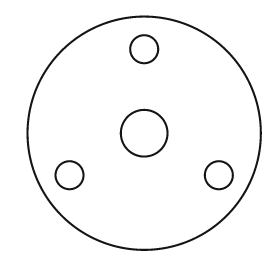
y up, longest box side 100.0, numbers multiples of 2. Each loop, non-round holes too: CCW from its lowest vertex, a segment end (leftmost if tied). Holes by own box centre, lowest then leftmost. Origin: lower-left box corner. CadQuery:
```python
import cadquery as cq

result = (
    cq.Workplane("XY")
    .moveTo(50.0, 50.0)
    .circle(50.0)
    .moveTo(18.0, 32.0)
    .circle(6.0)
    .moveTo(82.0, 32.0)
    .circle(6.0)
    .moveTo(50.0, 50.0)
    .circle(10.0)
    .moveTo(50.0, 86.0)
    .circle(6.0)
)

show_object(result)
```